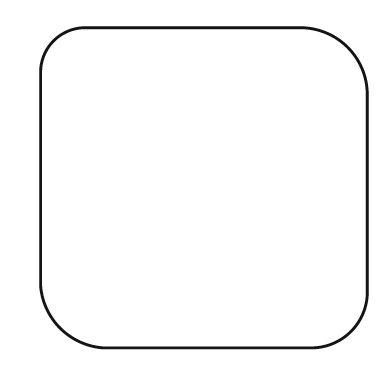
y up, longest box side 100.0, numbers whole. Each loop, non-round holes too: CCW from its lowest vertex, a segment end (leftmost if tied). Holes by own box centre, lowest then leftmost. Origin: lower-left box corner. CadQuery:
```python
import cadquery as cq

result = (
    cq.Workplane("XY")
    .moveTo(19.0, 0.0)
    .lineTo(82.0, 0.0)
    .threePointArc((95.0, 5.0), (100.0, 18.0))
    .lineTo(100.0, 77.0)
    .threePointArc((94.0, 92.0), (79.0, 98.0))
    .lineTo(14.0, 98.0)
    .threePointArc((4.0, 94.0), (0.0, 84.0))
    .lineTo(0.0, 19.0)
    .threePointArc((6.0, 6.0), (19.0, 0.0))
    .close()
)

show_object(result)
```